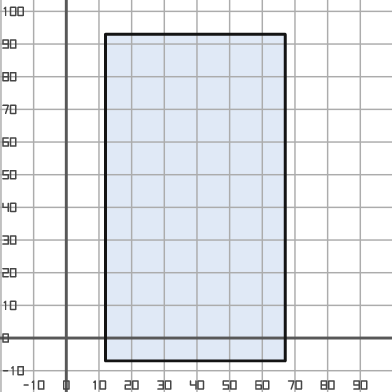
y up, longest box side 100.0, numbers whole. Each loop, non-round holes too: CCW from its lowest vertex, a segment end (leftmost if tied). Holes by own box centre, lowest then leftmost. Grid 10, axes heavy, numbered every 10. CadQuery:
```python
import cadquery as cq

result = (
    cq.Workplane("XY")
    .moveTo(12.0, -7.0)
    .lineTo(67.0, -7.0)
    .lineTo(67.0, 93.0)
    .lineTo(12.0, 93.0)
    .close()
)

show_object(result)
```